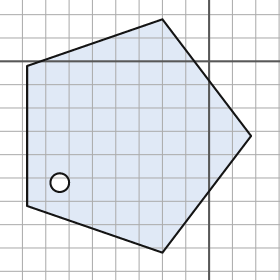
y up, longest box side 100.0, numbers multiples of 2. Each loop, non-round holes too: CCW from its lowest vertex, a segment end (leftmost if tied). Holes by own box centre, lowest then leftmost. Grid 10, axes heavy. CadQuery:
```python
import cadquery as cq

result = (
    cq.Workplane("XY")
    .moveTo(-20.0, -82.0)
    .lineTo(18.0, -32.0)
    .lineTo(-20.0, 18.0)
    .lineTo(-78.0, -2.0)
    .lineTo(-78.0, -62.0)
    .close()
    .moveTo(-64.0, -52.0)
    .circle(4.0)
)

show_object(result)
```